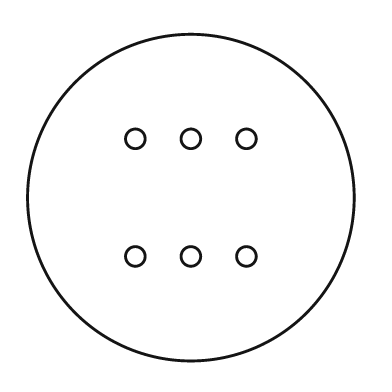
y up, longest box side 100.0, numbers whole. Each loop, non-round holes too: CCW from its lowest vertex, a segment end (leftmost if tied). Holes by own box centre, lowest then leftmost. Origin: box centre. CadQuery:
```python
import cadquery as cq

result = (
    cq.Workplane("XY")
    .moveTo(0.0, 0.0)
    .circle(50.0)
    .moveTo(-17.0, -18.0)
    .circle(3.0)
    .moveTo(0.0, -18.0)
    .circle(3.0)
    .moveTo(17.0, -18.0)
    .circle(3.0)
    .moveTo(-17.0, 18.0)
    .circle(3.0)
    .moveTo(0.0, 18.0)
    .circle(3.0)
    .moveTo(17.0, 18.0)
    .circle(3.0)
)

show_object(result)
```